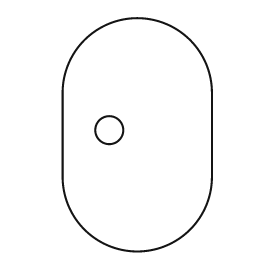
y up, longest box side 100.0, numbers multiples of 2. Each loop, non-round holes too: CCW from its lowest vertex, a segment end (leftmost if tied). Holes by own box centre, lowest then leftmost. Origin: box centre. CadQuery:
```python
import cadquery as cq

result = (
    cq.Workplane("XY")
    .moveTo(-32.0, -18.0)
    .threePointArc((0.0, -50.0), (32.0, -18.0))
    .lineTo(32.0, 18.0)
    .threePointArc((0.0, 50.0), (-32.0, 18.0))
    .close()
    .moveTo(-12.0, 2.0)
    .circle(6.0)
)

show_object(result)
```